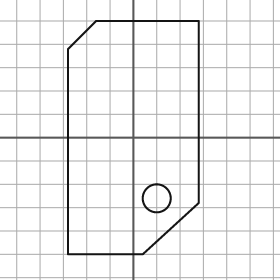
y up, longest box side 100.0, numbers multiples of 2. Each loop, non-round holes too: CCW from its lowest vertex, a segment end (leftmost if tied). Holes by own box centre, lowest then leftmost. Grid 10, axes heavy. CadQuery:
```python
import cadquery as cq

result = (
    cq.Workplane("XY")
    .moveTo(-28.0, -50.0)
    .lineTo(4.0, -50.0)
    .lineTo(28.0, -28.0)
    .lineTo(28.0, 50.0)
    .lineTo(-16.0, 50.0)
    .lineTo(-28.0, 38.0)
    .close()
    .moveTo(10.0, -26.0)
    .circle(6.0)
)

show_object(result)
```